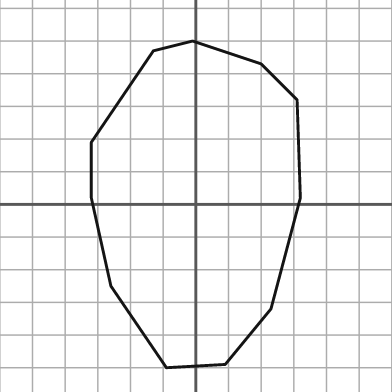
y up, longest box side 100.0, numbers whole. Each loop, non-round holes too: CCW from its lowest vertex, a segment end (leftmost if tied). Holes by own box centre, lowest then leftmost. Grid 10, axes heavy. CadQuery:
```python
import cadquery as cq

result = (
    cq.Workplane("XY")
    .moveTo(-9.0, -50.0)
    .lineTo(9.0, -49.0)
    .lineTo(23.0, -32.0)
    .lineTo(32.0, 2.0)
    .lineTo(31.0, 32.0)
    .lineTo(20.0, 43.0)
    .lineTo(-1.0, 50.0)
    .lineTo(-13.0, 47.0)
    .lineTo(-32.0, 19.0)
    .lineTo(-32.0, 2.0)
    .lineTo(-26.0, -25.0)
    .close()
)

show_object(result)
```